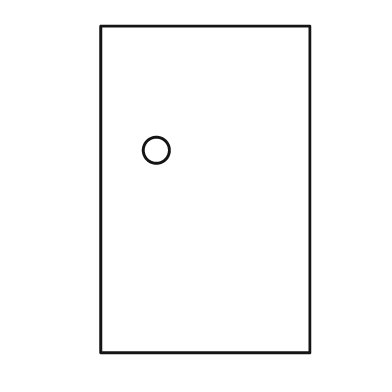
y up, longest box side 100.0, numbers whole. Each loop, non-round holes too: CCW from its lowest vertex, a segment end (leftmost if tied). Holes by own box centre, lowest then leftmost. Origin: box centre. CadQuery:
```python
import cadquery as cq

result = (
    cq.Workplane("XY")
    .moveTo(-32.0, -50.0)
    .lineTo(32.0, -50.0)
    .lineTo(32.0, 50.0)
    .lineTo(-32.0, 50.0)
    .close()
    .moveTo(-15.0, 12.0)
    .circle(4.0)
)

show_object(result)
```